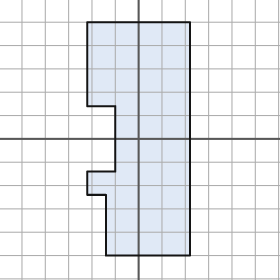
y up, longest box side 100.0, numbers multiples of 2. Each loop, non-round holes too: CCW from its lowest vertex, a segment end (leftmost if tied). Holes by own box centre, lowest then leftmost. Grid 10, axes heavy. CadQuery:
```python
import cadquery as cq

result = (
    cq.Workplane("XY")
    .moveTo(-14.0, -50.0)
    .lineTo(22.0, -50.0)
    .lineTo(22.0, 50.0)
    .lineTo(-22.0, 50.0)
    .lineTo(-22.0, 14.0)
    .lineTo(-10.0, 14.0)
    .lineTo(-10.0, -14.0)
    .lineTo(-22.0, -14.0)
    .lineTo(-22.0, -24.0)
    .lineTo(-14.0, -24.0)
    .close()
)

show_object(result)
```